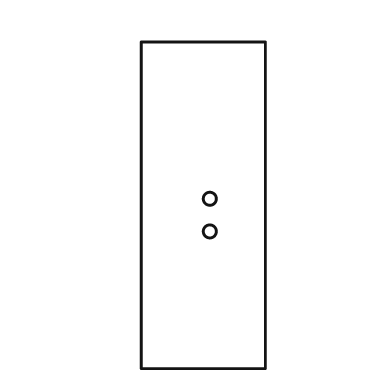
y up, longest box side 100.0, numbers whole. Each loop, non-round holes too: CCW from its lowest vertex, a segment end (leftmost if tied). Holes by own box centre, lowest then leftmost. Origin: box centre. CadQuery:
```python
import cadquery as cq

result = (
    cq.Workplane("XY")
    .moveTo(-19.0, -50.0)
    .lineTo(19.0, -50.0)
    .lineTo(19.0, 50.0)
    .lineTo(-19.0, 50.0)
    .close()
    .moveTo(2.0, -8.0)
    .circle(2.0)
    .moveTo(2.0, 2.0)
    .circle(2.0)
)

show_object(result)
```